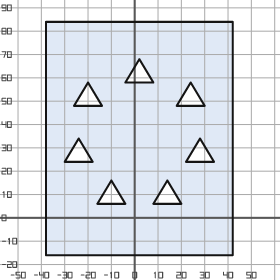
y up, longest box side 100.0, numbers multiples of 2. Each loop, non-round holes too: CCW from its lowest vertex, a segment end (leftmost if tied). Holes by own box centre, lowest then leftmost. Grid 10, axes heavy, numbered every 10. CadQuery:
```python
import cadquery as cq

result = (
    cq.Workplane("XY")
    .moveTo(-38.0, -16.0)
    .lineTo(42.0, -16.0)
    .lineTo(42.0, 84.0)
    .lineTo(-38.0, 84.0)
    .close()
    .moveTo(-16.0, 6.0)
    .lineTo(-4.0, 6.0)
    .lineTo(-10.0, 16.0)
    .close()
    .moveTo(8.0, 6.0)
    .lineTo(20.0, 6.0)
    .lineTo(14.0, 16.0)
    .close()
    .moveTo(-30.0, 24.0)
    .lineTo(-18.0, 24.0)
    .lineTo(-24.0, 34.0)
    .close()
    .moveTo(22.0, 24.0)
    .lineTo(34.0, 24.0)
    .lineTo(28.0, 34.0)
    .close()
    .moveTo(-26.0, 48.0)
    .lineTo(-14.0, 48.0)
    .lineTo(-20.0, 58.0)
    .close()
    .moveTo(18.0, 48.0)
    .lineTo(30.0, 48.0)
    .lineTo(24.0, 58.0)
    .close()
    .moveTo(-4.0, 58.0)
    .lineTo(8.0, 58.0)
    .lineTo(2.0, 68.0)
    .close()
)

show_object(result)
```